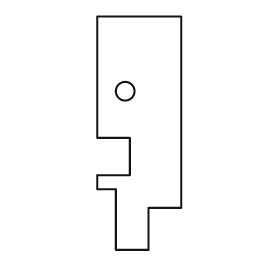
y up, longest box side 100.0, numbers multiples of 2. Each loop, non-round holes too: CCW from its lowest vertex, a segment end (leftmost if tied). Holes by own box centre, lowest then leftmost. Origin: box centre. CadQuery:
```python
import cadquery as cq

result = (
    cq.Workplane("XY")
    .moveTo(-10.0, -50.0)
    .lineTo(4.0, -50.0)
    .lineTo(4.0, -32.0)
    .lineTo(18.0, -32.0)
    .lineTo(18.0, 50.0)
    .lineTo(-18.0, 50.0)
    .lineTo(-18.0, -2.0)
    .lineTo(-4.0, -2.0)
    .lineTo(-4.0, -18.0)
    .lineTo(-18.0, -18.0)
    .lineTo(-18.0, -24.0)
    .lineTo(-10.0, -24.0)
    .close()
    .moveTo(-6.0, 18.0)
    .circle(4.0)
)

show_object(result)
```